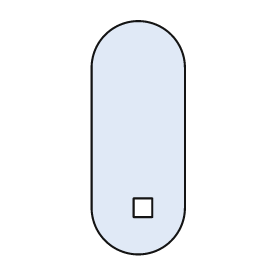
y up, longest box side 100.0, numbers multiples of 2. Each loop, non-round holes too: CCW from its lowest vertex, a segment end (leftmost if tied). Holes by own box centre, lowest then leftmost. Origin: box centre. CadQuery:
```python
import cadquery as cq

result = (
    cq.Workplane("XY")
    .moveTo(-20.0, -30.0)
    .threePointArc((0.0, -50.0), (20.0, -30.0))
    .lineTo(20.0, 30.0)
    .threePointArc((0.0, 50.0), (-20.0, 30.0))
    .close()
    .moveTo(-2.0, -34.0)
    .lineTo(6.0, -34.0)
    .lineTo(6.0, -26.0)
    .lineTo(-2.0, -26.0)
    .close()
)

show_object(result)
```